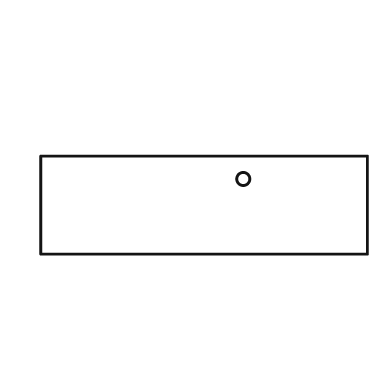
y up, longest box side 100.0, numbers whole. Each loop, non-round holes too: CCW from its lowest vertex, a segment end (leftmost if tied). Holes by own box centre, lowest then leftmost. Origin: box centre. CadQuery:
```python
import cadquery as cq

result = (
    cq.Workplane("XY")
    .moveTo(-50.0, -15.0)
    .lineTo(50.0, -15.0)
    .lineTo(50.0, 15.0)
    .lineTo(-50.0, 15.0)
    .close()
    .moveTo(12.0, 8.0)
    .circle(2.0)
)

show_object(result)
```